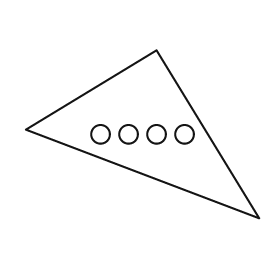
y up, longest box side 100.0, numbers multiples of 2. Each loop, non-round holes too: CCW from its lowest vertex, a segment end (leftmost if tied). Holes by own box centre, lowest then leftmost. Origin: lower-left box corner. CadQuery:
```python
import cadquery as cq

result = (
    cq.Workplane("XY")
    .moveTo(100.0, 0.0)
    .lineTo(56.0, 72.0)
    .lineTo(0.0, 38.0)
    .close()
    .moveTo(32.0, 36.0)
    .circle(4.0)
    .moveTo(44.0, 36.0)
    .circle(4.0)
    .moveTo(56.0, 36.0)
    .circle(4.0)
    .moveTo(68.0, 36.0)
    .circle(4.0)
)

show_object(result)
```